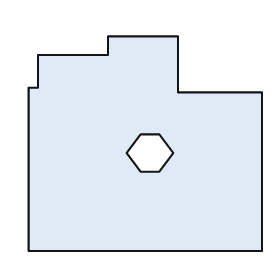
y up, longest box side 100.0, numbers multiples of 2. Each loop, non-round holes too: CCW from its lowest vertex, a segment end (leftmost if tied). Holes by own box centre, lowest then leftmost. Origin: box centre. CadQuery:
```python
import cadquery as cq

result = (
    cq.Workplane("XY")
    .moveTo(-50.0, -46.0)
    .lineTo(50.0, -46.0)
    .lineTo(50.0, 22.0)
    .lineTo(14.0, 22.0)
    .lineTo(14.0, 46.0)
    .lineTo(-16.0, 46.0)
    .lineTo(-16.0, 38.0)
    .lineTo(-46.0, 38.0)
    .lineTo(-46.0, 24.0)
    .lineTo(-50.0, 24.0)
    .close()
    .moveTo(-2.0, -12.0)
    .lineTo(6.0, -12.0)
    .lineTo(12.0, -4.0)
    .lineTo(6.0, 4.0)
    .lineTo(-2.0, 4.0)
    .lineTo(-8.0, -4.0)
    .close()
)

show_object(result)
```